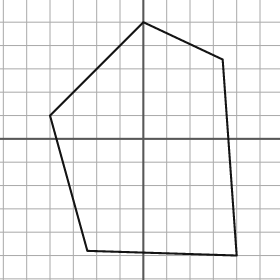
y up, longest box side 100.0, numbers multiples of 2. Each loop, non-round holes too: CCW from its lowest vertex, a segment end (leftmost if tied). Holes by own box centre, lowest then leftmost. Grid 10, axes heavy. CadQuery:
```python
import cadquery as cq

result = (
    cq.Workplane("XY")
    .moveTo(40.0, -50.0)
    .lineTo(34.0, 34.0)
    .lineTo(0.0, 50.0)
    .lineTo(-40.0, 10.0)
    .lineTo(-24.0, -48.0)
    .close()
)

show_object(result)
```